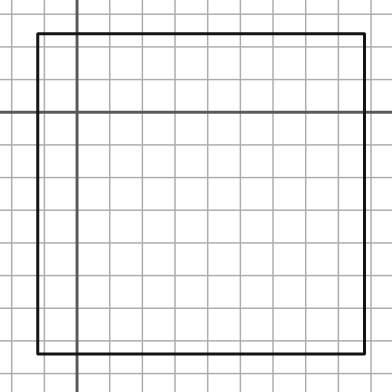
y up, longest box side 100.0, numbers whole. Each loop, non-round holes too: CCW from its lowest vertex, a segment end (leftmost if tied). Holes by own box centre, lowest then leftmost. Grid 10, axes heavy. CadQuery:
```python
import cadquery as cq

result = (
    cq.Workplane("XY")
    .moveTo(-12.0, -74.0)
    .lineTo(88.0, -74.0)
    .lineTo(88.0, 24.0)
    .lineTo(-12.0, 24.0)
    .close()
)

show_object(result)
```